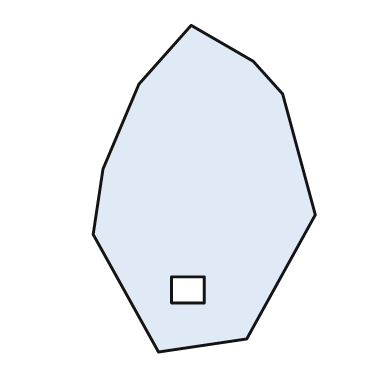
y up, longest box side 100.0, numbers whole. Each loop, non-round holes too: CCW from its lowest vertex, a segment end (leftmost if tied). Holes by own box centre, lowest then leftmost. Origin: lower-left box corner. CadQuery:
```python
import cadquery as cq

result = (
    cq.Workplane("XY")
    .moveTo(20.0, 0.0)
    .lineTo(47.0, 4.0)
    .lineTo(68.0, 42.0)
    .lineTo(58.0, 79.0)
    .lineTo(49.0, 89.0)
    .lineTo(30.0, 100.0)
    .lineTo(14.0, 82.0)
    .lineTo(3.0, 56.0)
    .lineTo(0.0, 36.0)
    .close()
    .moveTo(24.0, 15.0)
    .lineTo(34.0, 15.0)
    .lineTo(34.0, 23.0)
    .lineTo(24.0, 23.0)
    .close()
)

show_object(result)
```